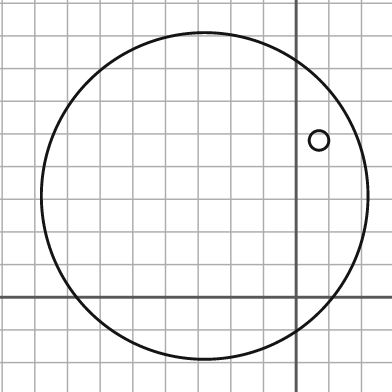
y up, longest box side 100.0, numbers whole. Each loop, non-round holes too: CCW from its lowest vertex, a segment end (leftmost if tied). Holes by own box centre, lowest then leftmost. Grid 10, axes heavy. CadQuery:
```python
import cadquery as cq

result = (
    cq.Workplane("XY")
    .moveTo(-28.0, 31.0)
    .circle(50.0)
    .moveTo(7.0, 48.0)
    .circle(3.0)
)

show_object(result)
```